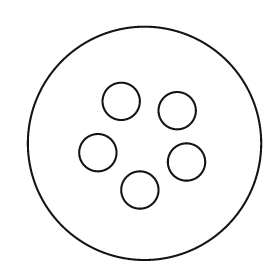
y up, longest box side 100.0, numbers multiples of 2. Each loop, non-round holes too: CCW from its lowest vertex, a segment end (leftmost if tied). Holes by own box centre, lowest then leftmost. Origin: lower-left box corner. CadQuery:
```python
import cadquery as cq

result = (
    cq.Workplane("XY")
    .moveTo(50.0, 50.0)
    .circle(50.0)
    .moveTo(48.0, 30.0)
    .circle(8.0)
    .moveTo(68.0, 42.0)
    .circle(8.0)
    .moveTo(30.0, 46.0)
    .circle(8.0)
    .moveTo(64.0, 64.0)
    .circle(8.0)
    .moveTo(40.0, 68.0)
    .circle(8.0)
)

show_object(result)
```